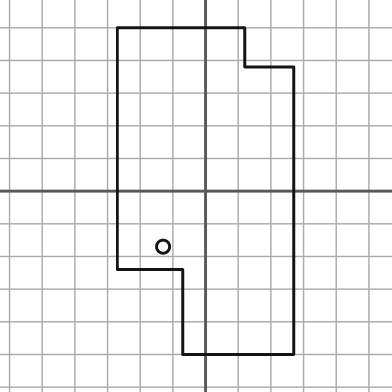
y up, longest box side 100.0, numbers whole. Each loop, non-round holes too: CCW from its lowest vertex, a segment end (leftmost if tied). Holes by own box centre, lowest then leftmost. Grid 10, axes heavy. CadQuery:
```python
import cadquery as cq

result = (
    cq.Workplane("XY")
    .moveTo(-7.0, -50.0)
    .lineTo(27.0, -50.0)
    .lineTo(27.0, 38.0)
    .lineTo(12.0, 38.0)
    .lineTo(12.0, 50.0)
    .lineTo(-27.0, 50.0)
    .lineTo(-27.0, -24.0)
    .lineTo(-7.0, -24.0)
    .close()
    .moveTo(-13.0, -17.0)
    .circle(2.0)
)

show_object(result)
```